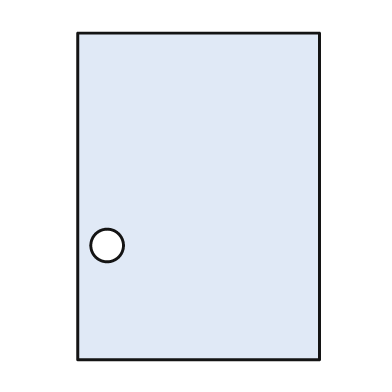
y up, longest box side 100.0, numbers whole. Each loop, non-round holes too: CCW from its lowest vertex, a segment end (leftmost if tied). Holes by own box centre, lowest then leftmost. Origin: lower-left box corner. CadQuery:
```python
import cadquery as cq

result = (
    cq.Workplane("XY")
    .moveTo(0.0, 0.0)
    .lineTo(74.0, 0.0)
    .lineTo(74.0, 100.0)
    .lineTo(0.0, 100.0)
    .close()
    .moveTo(9.0, 35.0)
    .circle(5.0)
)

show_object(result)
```